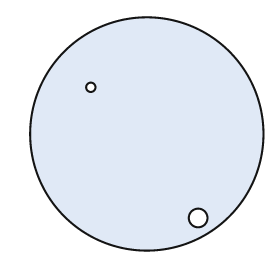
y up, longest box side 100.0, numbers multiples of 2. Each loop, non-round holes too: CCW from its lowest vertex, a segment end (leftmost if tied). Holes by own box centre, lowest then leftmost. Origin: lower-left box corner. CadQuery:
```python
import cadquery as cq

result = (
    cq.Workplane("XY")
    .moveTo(50.0, 50.0)
    .circle(50.0)
    .moveTo(72.0, 14.0)
    .circle(4.0)
    .moveTo(26.0, 70.0)
    .circle(2.0)
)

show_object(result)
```